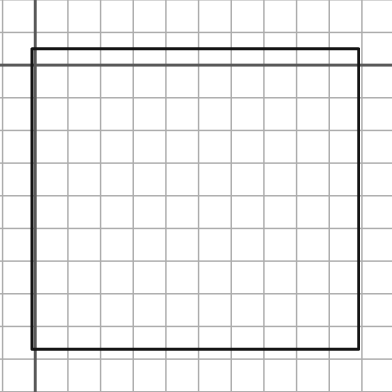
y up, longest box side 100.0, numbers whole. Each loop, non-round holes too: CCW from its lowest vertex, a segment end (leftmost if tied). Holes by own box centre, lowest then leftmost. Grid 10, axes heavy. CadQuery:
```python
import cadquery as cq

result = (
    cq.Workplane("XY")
    .moveTo(-1.0, -87.0)
    .lineTo(99.0, -87.0)
    .lineTo(99.0, 5.0)
    .lineTo(-1.0, 5.0)
    .close()
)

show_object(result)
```